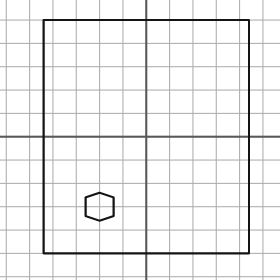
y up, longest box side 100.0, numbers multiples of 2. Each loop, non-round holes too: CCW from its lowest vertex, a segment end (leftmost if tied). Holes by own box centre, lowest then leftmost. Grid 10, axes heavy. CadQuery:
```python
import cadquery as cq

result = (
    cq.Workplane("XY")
    .moveTo(-44.0, -50.0)
    .lineTo(44.0, -50.0)
    .lineTo(44.0, 50.0)
    .lineTo(-44.0, 50.0)
    .close()
    .moveTo(-20.0, -36.0)
    .lineTo(-14.0, -34.0)
    .lineTo(-14.0, -26.0)
    .lineTo(-20.0, -24.0)
    .lineTo(-26.0, -26.0)
    .lineTo(-26.0, -34.0)
    .close()
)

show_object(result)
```